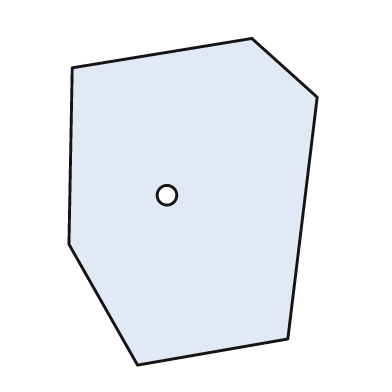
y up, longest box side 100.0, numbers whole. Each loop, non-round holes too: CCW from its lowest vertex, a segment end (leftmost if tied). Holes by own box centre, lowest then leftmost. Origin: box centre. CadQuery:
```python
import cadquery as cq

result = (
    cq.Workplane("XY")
    .moveTo(-17.0, -50.0)
    .lineTo(29.0, -42.0)
    .lineTo(38.0, 32.0)
    .lineTo(18.0, 50.0)
    .lineTo(-37.0, 41.0)
    .lineTo(-38.0, -13.0)
    .close()
    .moveTo(-8.0, 2.0)
    .circle(3.0)
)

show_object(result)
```